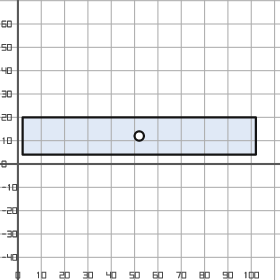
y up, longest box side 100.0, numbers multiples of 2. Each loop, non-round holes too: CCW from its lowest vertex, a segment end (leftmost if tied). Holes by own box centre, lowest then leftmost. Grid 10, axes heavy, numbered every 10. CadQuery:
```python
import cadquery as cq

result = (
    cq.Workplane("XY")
    .moveTo(2.0, 4.0)
    .lineTo(102.0, 4.0)
    .lineTo(102.0, 20.0)
    .lineTo(2.0, 20.0)
    .close()
    .moveTo(52.0, 12.0)
    .circle(2.0)
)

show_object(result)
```